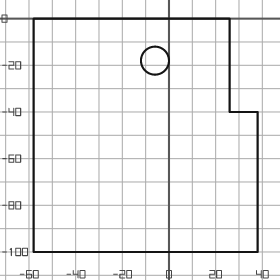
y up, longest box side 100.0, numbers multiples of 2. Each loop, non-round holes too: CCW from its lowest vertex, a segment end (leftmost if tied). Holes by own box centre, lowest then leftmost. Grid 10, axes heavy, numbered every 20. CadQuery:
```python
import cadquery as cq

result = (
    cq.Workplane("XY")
    .moveTo(-58.0, -100.0)
    .lineTo(38.0, -100.0)
    .lineTo(38.0, -40.0)
    .lineTo(26.0, -40.0)
    .lineTo(26.0, 0.0)
    .lineTo(-58.0, 0.0)
    .close()
    .moveTo(-6.0, -18.0)
    .circle(6.0)
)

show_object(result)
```